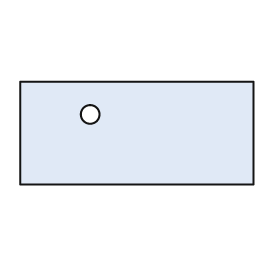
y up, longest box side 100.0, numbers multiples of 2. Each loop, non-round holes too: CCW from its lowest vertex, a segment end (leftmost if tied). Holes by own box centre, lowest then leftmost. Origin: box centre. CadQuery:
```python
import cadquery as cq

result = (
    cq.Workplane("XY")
    .moveTo(-50.0, -22.0)
    .lineTo(50.0, -22.0)
    .lineTo(50.0, 22.0)
    .lineTo(-50.0, 22.0)
    .close()
    .moveTo(-20.0, 8.0)
    .circle(4.0)
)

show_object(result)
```